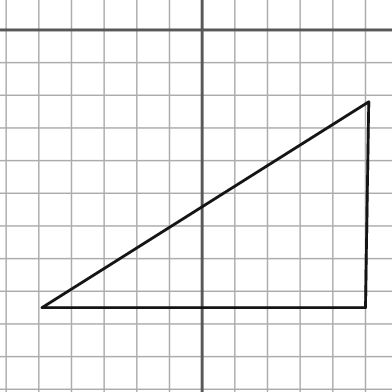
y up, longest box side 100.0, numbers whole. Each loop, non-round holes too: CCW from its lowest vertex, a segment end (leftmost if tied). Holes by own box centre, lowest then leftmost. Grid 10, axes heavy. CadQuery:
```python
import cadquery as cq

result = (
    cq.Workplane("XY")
    .moveTo(-49.0, -85.0)
    .lineTo(50.0, -85.0)
    .lineTo(51.0, -22.0)
    .close()
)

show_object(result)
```